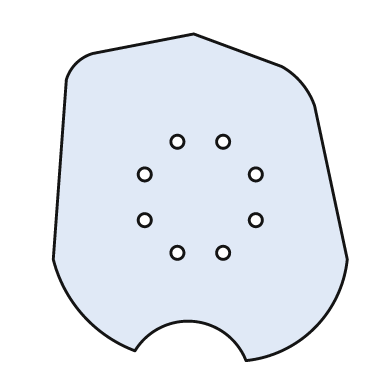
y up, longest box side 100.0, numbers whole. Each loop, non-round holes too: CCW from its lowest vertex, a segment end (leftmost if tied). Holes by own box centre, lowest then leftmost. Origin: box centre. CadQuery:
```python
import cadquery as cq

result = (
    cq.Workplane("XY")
    .moveTo(14.0, -50.0)
    .threePointArc((35.0, -40.0), (45.0, -19.0))
    .lineTo(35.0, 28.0)
    .threePointArc((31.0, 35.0), (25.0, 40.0))
    .lineTo(-2.0, 50.0)
    .lineTo(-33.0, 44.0)
    .threePointArc((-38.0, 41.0), (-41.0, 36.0))
    .lineTo(-45.0, -19.0)
    .threePointArc((-36.0, -36.0), (-20.0, -47.0))
    .threePointArc((-2.0, -38.0), (14.0, -50.0))
    .close()
    .moveTo(-7.0, -17.0)
    .circle(2.0)
    .moveTo(7.0, -17.0)
    .circle(2.0)
    .moveTo(-17.0, -7.0)
    .circle(2.0)
    .moveTo(17.0, -7.0)
    .circle(2.0)
    .moveTo(-17.0, 7.0)
    .circle(2.0)
    .moveTo(17.0, 7.0)
    .circle(2.0)
    .moveTo(-7.0, 17.0)
    .circle(2.0)
    .moveTo(7.0, 17.0)
    .circle(2.0)
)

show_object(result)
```